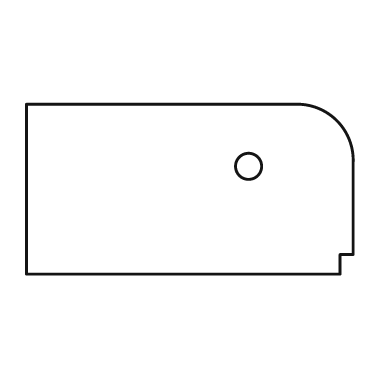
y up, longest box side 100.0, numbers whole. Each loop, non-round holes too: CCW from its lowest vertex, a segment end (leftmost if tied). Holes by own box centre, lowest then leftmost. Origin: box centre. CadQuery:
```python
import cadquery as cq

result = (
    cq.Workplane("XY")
    .moveTo(-50.0, -26.0)
    .lineTo(46.0, -26.0)
    .lineTo(46.0, -20.0)
    .lineTo(50.0, -20.0)
    .lineTo(50.0, 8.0)
    .threePointArc((45.0, 21.0), (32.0, 26.0))
    .lineTo(-50.0, 26.0)
    .close()
    .moveTo(18.0, 7.0)
    .circle(4.0)
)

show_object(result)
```